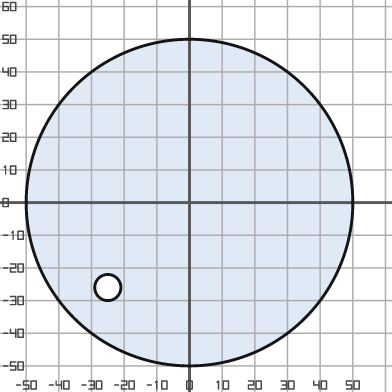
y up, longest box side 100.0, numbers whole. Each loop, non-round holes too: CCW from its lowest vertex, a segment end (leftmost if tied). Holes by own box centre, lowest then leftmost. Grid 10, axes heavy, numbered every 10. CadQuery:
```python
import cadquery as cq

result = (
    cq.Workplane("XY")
    .moveTo(0.0, 0.0)
    .circle(50.0)
    .moveTo(-25.0, -26.0)
    .circle(4.0)
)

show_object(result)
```